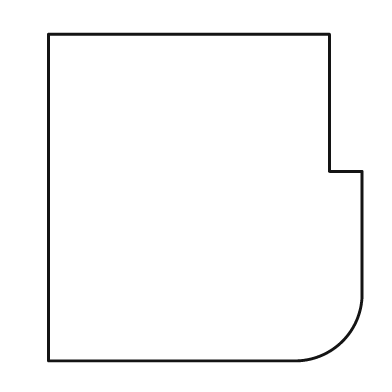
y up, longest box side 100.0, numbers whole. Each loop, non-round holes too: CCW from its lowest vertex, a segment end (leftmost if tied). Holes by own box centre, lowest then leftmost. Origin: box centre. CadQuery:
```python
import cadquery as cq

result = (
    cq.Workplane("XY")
    .moveTo(-48.0, -50.0)
    .lineTo(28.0, -50.0)
    .threePointArc((42.0, -44.0), (48.0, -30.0))
    .lineTo(48.0, 8.0)
    .lineTo(38.0, 8.0)
    .lineTo(38.0, 50.0)
    .lineTo(-48.0, 50.0)
    .close()
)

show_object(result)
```